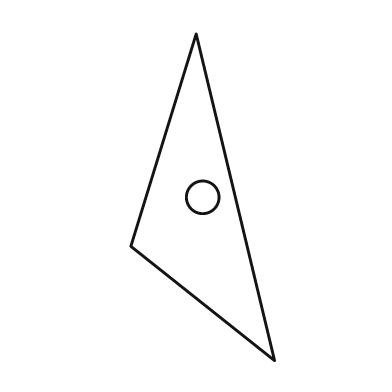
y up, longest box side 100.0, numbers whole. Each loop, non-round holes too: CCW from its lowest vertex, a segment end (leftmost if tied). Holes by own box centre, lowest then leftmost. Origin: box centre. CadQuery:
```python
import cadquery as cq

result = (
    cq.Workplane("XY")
    .moveTo(22.0, -50.0)
    .lineTo(-2.0, 50.0)
    .lineTo(-22.0, -15.0)
    .close()
    .moveTo(0.0, 0.0)
    .circle(5.0)
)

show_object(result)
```